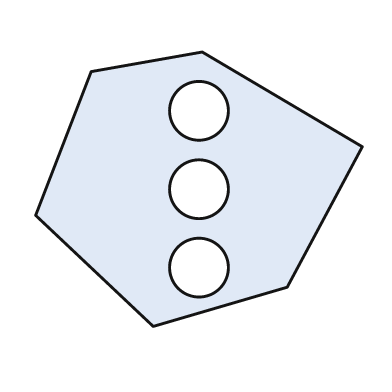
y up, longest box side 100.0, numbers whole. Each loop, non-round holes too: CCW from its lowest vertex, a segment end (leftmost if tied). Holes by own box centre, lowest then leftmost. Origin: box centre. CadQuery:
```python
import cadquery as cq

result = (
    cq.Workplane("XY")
    .moveTo(-14.0, -42.0)
    .lineTo(27.0, -30.0)
    .lineTo(50.0, 13.0)
    .lineTo(1.0, 42.0)
    .lineTo(-33.0, 36.0)
    .lineTo(-50.0, -8.0)
    .close()
    .moveTo(0.0, -24.0)
    .circle(9.0)
    .moveTo(0.0, 0.0)
    .circle(9.0)
    .moveTo(0.0, 24.0)
    .circle(9.0)
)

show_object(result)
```